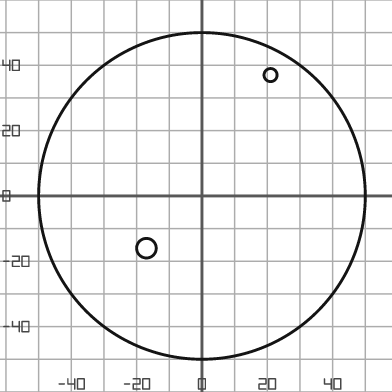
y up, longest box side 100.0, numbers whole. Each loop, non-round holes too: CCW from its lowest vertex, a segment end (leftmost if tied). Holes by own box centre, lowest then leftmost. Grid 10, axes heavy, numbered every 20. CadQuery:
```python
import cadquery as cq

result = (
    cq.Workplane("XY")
    .moveTo(0.0, 0.0)
    .circle(50.0)
    .moveTo(-17.0, -16.0)
    .circle(3.0)
    .moveTo(21.0, 37.0)
    .circle(2.0)
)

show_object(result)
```